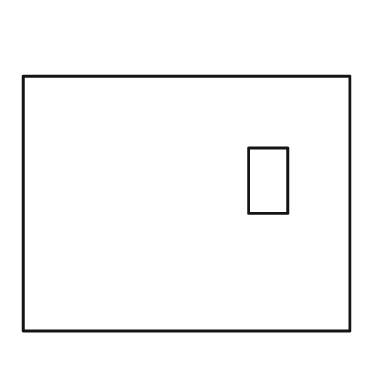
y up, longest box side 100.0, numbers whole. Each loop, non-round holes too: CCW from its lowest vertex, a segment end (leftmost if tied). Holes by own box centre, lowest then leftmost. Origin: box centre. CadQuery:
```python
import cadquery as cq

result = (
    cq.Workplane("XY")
    .moveTo(-50.0, -39.0)
    .lineTo(50.0, -39.0)
    .lineTo(50.0, 39.0)
    .lineTo(-50.0, 39.0)
    .close()
    .moveTo(19.0, -3.0)
    .lineTo(31.0, -3.0)
    .lineTo(31.0, 17.0)
    .lineTo(19.0, 17.0)
    .close()
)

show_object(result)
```